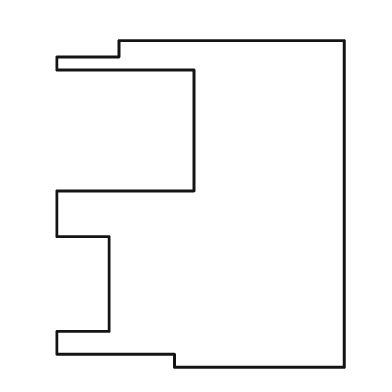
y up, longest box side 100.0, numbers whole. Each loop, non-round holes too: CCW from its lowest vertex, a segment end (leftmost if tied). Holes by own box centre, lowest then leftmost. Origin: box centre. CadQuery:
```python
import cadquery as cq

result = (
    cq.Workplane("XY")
    .moveTo(-8.0, -50.0)
    .lineTo(44.0, -50.0)
    .lineTo(44.0, 50.0)
    .lineTo(-25.0, 50.0)
    .lineTo(-25.0, 45.0)
    .lineTo(-44.0, 45.0)
    .lineTo(-44.0, 41.0)
    .lineTo(-2.0, 41.0)
    .lineTo(-2.0, 4.0)
    .lineTo(-44.0, 4.0)
    .lineTo(-44.0, -10.0)
    .lineTo(-28.0, -10.0)
    .lineTo(-28.0, -39.0)
    .lineTo(-44.0, -39.0)
    .lineTo(-44.0, -46.0)
    .lineTo(-8.0, -46.0)
    .close()
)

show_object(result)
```